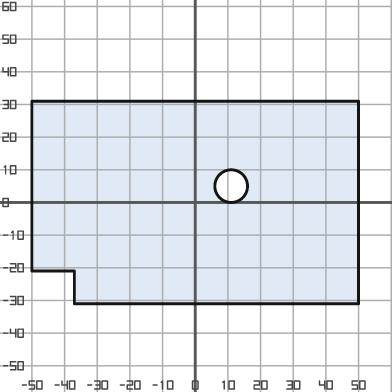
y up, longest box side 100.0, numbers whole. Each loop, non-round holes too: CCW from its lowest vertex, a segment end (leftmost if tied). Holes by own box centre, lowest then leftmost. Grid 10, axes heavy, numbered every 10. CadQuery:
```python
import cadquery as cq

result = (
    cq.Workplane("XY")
    .moveTo(-37.0, -31.0)
    .lineTo(50.0, -31.0)
    .lineTo(50.0, 31.0)
    .lineTo(-50.0, 31.0)
    .lineTo(-50.0, -21.0)
    .lineTo(-37.0, -21.0)
    .close()
    .moveTo(11.0, 5.0)
    .circle(5.0)
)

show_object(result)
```